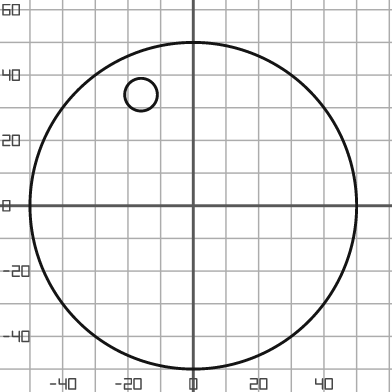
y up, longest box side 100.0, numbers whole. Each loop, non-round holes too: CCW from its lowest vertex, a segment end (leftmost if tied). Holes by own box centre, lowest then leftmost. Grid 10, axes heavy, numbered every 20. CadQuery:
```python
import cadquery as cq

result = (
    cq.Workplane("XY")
    .moveTo(0.0, 0.0)
    .circle(50.0)
    .moveTo(-16.0, 34.0)
    .circle(5.0)
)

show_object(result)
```